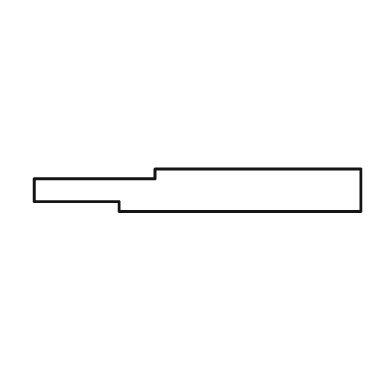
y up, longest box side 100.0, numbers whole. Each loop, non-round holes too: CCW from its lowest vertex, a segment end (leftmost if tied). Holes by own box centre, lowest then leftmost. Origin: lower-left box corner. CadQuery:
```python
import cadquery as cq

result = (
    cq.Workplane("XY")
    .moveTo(26.0, 0.0)
    .lineTo(100.0, 0.0)
    .lineTo(100.0, 13.0)
    .lineTo(37.0, 13.0)
    .lineTo(37.0, 10.0)
    .lineTo(0.0, 10.0)
    .lineTo(0.0, 3.0)
    .lineTo(26.0, 3.0)
    .close()
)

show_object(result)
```